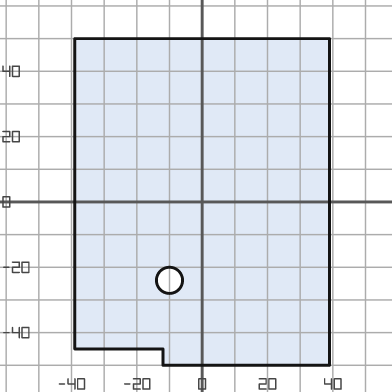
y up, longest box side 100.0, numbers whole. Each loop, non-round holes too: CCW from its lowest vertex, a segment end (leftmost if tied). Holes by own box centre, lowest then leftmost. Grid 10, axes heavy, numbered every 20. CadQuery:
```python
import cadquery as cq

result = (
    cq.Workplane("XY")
    .moveTo(-12.0, -50.0)
    .lineTo(39.0, -50.0)
    .lineTo(39.0, 50.0)
    .lineTo(-39.0, 50.0)
    .lineTo(-39.0, -45.0)
    .lineTo(-12.0, -45.0)
    .close()
    .moveTo(-10.0, -24.0)
    .circle(4.0)
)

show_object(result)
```